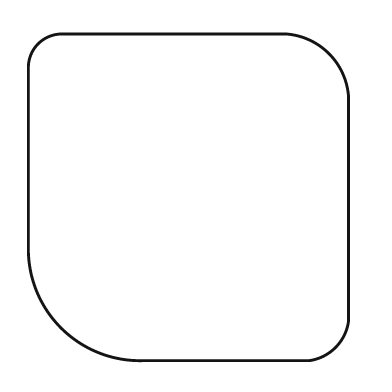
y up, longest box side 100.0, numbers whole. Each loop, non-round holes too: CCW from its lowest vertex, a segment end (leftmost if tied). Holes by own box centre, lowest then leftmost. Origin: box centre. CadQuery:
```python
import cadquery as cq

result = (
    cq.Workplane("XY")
    .moveTo(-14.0, -50.0)
    .lineTo(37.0, -50.0)
    .threePointArc((45.0, -46.0), (49.0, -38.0))
    .lineTo(49.0, 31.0)
    .threePointArc((43.0, 44.0), (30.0, 50.0))
    .lineTo(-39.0, 50.0)
    .threePointArc((-46.0, 47.0), (-49.0, 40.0))
    .lineTo(-49.0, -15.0)
    .threePointArc((-39.0, -40.0), (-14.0, -50.0))
    .close()
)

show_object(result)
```